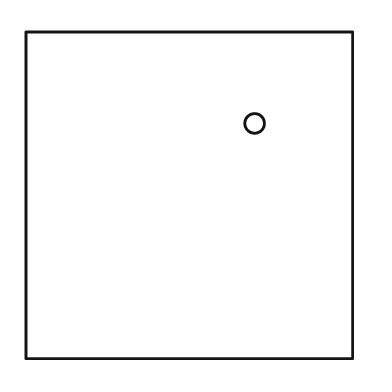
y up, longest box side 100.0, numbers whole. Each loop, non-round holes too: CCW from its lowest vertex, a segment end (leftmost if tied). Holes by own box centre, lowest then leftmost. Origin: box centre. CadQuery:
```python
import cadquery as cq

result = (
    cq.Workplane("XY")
    .moveTo(-50.0, -50.0)
    .lineTo(50.0, -50.0)
    .lineTo(50.0, 50.0)
    .lineTo(-50.0, 50.0)
    .close()
    .moveTo(20.0, 22.0)
    .circle(3.0)
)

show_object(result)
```